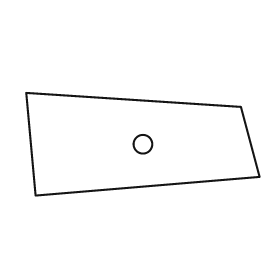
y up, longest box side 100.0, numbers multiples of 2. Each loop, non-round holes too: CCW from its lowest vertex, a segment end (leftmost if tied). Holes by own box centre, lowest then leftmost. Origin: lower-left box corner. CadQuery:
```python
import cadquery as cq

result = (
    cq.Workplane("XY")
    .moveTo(4.0, 0.0)
    .lineTo(100.0, 8.0)
    .lineTo(92.0, 38.0)
    .lineTo(0.0, 44.0)
    .close()
    .moveTo(50.0, 22.0)
    .circle(4.0)
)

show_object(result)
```